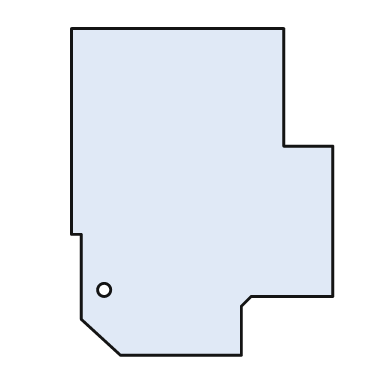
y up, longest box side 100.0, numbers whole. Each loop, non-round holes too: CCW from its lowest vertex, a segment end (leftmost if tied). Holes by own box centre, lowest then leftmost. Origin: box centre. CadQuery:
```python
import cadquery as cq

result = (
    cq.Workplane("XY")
    .moveTo(-25.0, -50.0)
    .lineTo(12.0, -50.0)
    .lineTo(12.0, -35.0)
    .lineTo(15.0, -32.0)
    .lineTo(40.0, -32.0)
    .lineTo(40.0, 14.0)
    .lineTo(25.0, 14.0)
    .lineTo(25.0, 50.0)
    .lineTo(-40.0, 50.0)
    .lineTo(-40.0, -13.0)
    .lineTo(-37.0, -13.0)
    .lineTo(-37.0, -39.0)
    .close()
    .moveTo(-30.0, -30.0)
    .circle(2.0)
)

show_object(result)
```